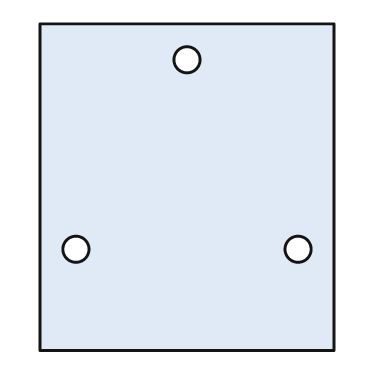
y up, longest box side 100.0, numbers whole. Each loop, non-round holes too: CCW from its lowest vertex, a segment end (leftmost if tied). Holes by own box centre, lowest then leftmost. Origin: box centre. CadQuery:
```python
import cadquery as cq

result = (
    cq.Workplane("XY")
    .moveTo(-45.0, -50.0)
    .lineTo(45.0, -50.0)
    .lineTo(45.0, 50.0)
    .lineTo(-45.0, 50.0)
    .close()
    .moveTo(-34.0, -19.0)
    .circle(4.0)
    .moveTo(34.0, -19.0)
    .circle(4.0)
    .moveTo(0.0, 39.0)
    .circle(4.0)
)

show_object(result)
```